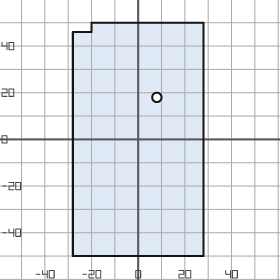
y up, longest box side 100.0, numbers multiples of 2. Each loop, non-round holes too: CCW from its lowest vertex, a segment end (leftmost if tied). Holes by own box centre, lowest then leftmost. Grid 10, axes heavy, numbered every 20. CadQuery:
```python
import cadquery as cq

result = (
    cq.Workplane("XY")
    .moveTo(-28.0, -50.0)
    .lineTo(28.0, -50.0)
    .lineTo(28.0, 50.0)
    .lineTo(-20.0, 50.0)
    .lineTo(-20.0, 46.0)
    .lineTo(-28.0, 46.0)
    .close()
    .moveTo(8.0, 18.0)
    .circle(2.0)
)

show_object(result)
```